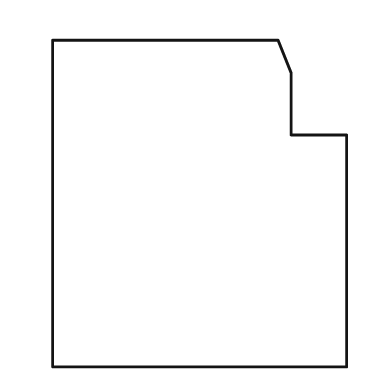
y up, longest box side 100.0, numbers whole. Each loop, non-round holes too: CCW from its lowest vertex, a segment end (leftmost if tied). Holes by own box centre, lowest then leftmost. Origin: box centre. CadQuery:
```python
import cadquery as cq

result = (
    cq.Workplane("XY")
    .moveTo(-45.0, -50.0)
    .lineTo(45.0, -50.0)
    .lineTo(45.0, 21.0)
    .lineTo(28.0, 21.0)
    .lineTo(28.0, 40.0)
    .lineTo(24.0, 50.0)
    .lineTo(-45.0, 50.0)
    .close()
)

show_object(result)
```